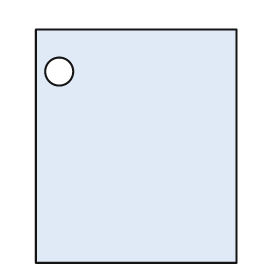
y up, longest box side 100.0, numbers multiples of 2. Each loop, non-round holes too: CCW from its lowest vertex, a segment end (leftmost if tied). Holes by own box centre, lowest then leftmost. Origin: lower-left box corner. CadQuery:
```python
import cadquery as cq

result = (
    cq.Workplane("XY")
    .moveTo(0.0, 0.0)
    .lineTo(86.0, 0.0)
    .lineTo(86.0, 100.0)
    .lineTo(0.0, 100.0)
    .close()
    .moveTo(10.0, 82.0)
    .circle(6.0)
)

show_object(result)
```